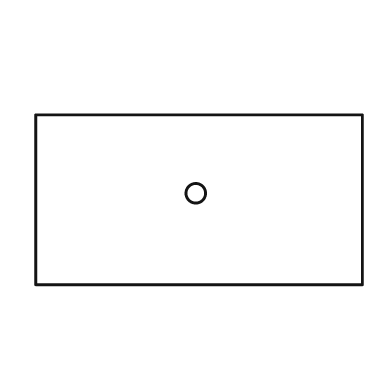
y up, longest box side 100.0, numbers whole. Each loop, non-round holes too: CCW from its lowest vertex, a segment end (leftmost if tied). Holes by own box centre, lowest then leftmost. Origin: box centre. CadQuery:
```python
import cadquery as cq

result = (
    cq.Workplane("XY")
    .moveTo(-50.0, -26.0)
    .lineTo(50.0, -26.0)
    .lineTo(50.0, 26.0)
    .lineTo(-50.0, 26.0)
    .close()
    .moveTo(-1.0, 2.0)
    .circle(3.0)
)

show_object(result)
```